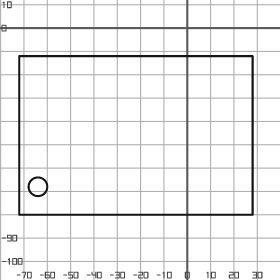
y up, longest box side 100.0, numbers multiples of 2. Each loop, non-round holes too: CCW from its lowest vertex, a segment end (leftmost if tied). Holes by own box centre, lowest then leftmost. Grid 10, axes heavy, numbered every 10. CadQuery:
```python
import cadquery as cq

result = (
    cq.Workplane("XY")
    .moveTo(-72.0, -80.0)
    .lineTo(28.0, -80.0)
    .lineTo(28.0, -12.0)
    .lineTo(-72.0, -12.0)
    .close()
    .moveTo(-64.0, -68.0)
    .circle(4.0)
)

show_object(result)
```